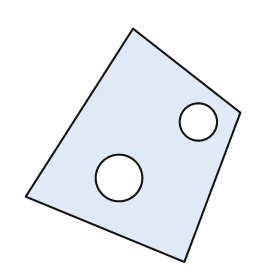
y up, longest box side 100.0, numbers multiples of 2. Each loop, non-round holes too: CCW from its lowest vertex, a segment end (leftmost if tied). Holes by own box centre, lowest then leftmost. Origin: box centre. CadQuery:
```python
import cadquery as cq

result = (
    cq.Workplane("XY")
    .moveTo(22.0, -50.0)
    .lineTo(46.0, 14.0)
    .lineTo(0.0, 50.0)
    .lineTo(-46.0, -22.0)
    .close()
    .moveTo(-6.0, -14.0)
    .circle(10.0)
    .moveTo(28.0, 10.0)
    .circle(8.0)
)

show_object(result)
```